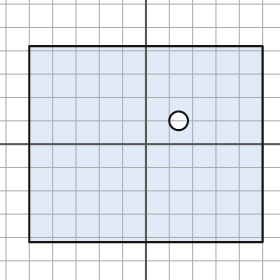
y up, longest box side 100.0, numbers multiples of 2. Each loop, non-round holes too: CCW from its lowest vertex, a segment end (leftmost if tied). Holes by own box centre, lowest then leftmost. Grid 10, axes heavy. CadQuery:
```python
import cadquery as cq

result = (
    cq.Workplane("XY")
    .moveTo(-50.0, -42.0)
    .lineTo(50.0, -42.0)
    .lineTo(50.0, 42.0)
    .lineTo(-50.0, 42.0)
    .close()
    .moveTo(14.0, 10.0)
    .circle(4.0)
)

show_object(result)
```